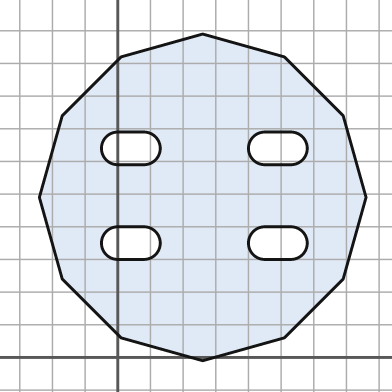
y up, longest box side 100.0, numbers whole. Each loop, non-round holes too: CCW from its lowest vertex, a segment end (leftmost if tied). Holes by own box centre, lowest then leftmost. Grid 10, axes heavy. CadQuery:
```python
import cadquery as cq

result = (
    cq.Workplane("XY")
    .moveTo(26.0, -1.0)
    .lineTo(51.0, 6.0)
    .lineTo(69.0, 24.0)
    .lineTo(76.0, 49.0)
    .lineTo(69.0, 74.0)
    .lineTo(51.0, 92.0)
    .lineTo(26.0, 99.0)
    .lineTo(1.0, 92.0)
    .lineTo(-17.0, 74.0)
    .lineTo(-24.0, 49.0)
    .lineTo(-17.0, 24.0)
    .lineTo(1.0, 6.0)
    .close()
    .moveTo(0.0, 30.0)
    .lineTo(8.0, 30.0)
    .threePointArc((13.0, 35.0), (8.0, 40.0))
    .lineTo(0.0, 40.0)
    .threePointArc((-5.0, 35.0), (0.0, 30.0))
    .close()
    .moveTo(45.0, 30.0)
    .lineTo(53.0, 30.0)
    .threePointArc((58.0, 35.0), (53.0, 40.0))
    .lineTo(45.0, 40.0)
    .threePointArc((40.0, 35.0), (45.0, 30.0))
    .close()
    .moveTo(0.0, 59.0)
    .lineTo(8.0, 59.0)
    .threePointArc((13.0, 64.0), (8.0, 69.0))
    .lineTo(0.0, 69.0)
    .threePointArc((-5.0, 64.0), (0.0, 59.0))
    .close()
    .moveTo(45.0, 59.0)
    .lineTo(53.0, 59.0)
    .threePointArc((58.0, 64.0), (53.0, 69.0))
    .lineTo(45.0, 69.0)
    .threePointArc((40.0, 64.0), (45.0, 59.0))
    .close()
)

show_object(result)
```